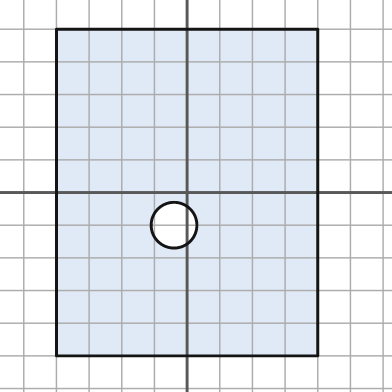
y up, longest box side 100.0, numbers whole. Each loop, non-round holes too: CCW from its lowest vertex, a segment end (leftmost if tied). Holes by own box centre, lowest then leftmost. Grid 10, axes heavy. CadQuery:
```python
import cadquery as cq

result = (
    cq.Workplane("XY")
    .moveTo(-40.0, -50.0)
    .lineTo(40.0, -50.0)
    .lineTo(40.0, 50.0)
    .lineTo(-40.0, 50.0)
    .close()
    .moveTo(-4.0, -10.0)
    .circle(7.0)
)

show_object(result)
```